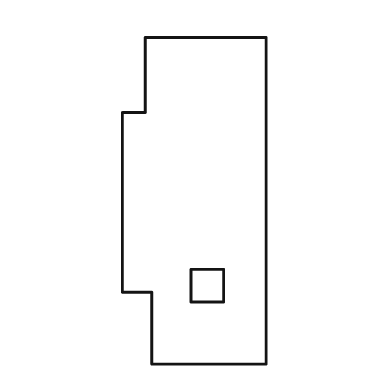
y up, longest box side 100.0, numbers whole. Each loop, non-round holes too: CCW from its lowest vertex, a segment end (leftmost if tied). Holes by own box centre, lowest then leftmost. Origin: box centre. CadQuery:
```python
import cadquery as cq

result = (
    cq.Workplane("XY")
    .moveTo(-13.0, -50.0)
    .lineTo(22.0, -50.0)
    .lineTo(22.0, 50.0)
    .lineTo(-15.0, 50.0)
    .lineTo(-15.0, 27.0)
    .lineTo(-22.0, 27.0)
    .lineTo(-22.0, -28.0)
    .lineTo(-13.0, -28.0)
    .close()
    .moveTo(-1.0, -31.0)
    .lineTo(9.0, -31.0)
    .lineTo(9.0, -21.0)
    .lineTo(-1.0, -21.0)
    .close()
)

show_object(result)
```